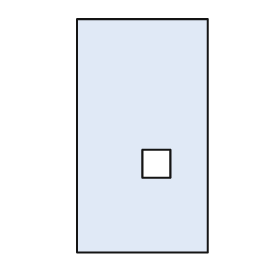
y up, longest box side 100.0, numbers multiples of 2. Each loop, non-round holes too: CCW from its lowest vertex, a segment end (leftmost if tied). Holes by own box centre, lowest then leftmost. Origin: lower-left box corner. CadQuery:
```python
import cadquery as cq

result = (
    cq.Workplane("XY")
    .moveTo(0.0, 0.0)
    .lineTo(56.0, 0.0)
    .lineTo(56.0, 100.0)
    .lineTo(0.0, 100.0)
    .close()
    .moveTo(28.0, 32.0)
    .lineTo(40.0, 32.0)
    .lineTo(40.0, 44.0)
    .lineTo(28.0, 44.0)
    .close()
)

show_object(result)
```